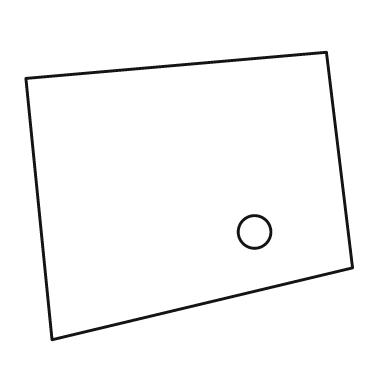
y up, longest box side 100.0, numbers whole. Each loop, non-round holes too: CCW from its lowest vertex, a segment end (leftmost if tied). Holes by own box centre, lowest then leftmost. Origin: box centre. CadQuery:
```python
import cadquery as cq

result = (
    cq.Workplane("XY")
    .moveTo(-42.0, -44.0)
    .lineTo(50.0, -22.0)
    .lineTo(42.0, 44.0)
    .lineTo(-50.0, 36.0)
    .close()
    .moveTo(20.0, -11.0)
    .circle(5.0)
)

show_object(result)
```